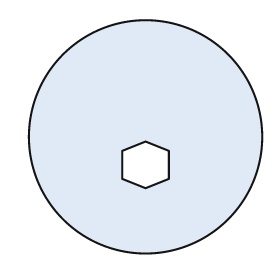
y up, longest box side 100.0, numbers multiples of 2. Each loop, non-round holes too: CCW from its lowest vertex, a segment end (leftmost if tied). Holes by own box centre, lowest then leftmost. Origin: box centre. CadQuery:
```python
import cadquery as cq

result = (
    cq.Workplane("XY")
    .moveTo(0.0, 0.0)
    .circle(50.0)
    .moveTo(0.0, -22.0)
    .lineTo(10.0, -18.0)
    .lineTo(10.0, -6.0)
    .lineTo(0.0, -2.0)
    .lineTo(-10.0, -6.0)
    .lineTo(-10.0, -18.0)
    .close()
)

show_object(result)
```